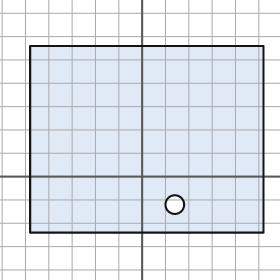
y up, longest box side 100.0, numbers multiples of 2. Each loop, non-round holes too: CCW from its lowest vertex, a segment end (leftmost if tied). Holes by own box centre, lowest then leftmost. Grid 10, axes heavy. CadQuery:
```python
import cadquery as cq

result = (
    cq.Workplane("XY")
    .moveTo(-48.0, -24.0)
    .lineTo(52.0, -24.0)
    .lineTo(52.0, 56.0)
    .lineTo(-48.0, 56.0)
    .close()
    .moveTo(14.0, -12.0)
    .circle(4.0)
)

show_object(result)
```